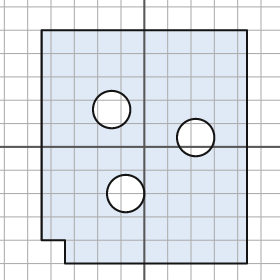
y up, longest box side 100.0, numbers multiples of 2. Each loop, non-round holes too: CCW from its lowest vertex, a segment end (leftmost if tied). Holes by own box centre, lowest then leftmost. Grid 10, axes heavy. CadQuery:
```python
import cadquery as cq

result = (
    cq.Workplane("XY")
    .moveTo(-34.0, -50.0)
    .lineTo(44.0, -50.0)
    .lineTo(44.0, 50.0)
    .lineTo(-44.0, 50.0)
    .lineTo(-44.0, -40.0)
    .lineTo(-34.0, -40.0)
    .close()
    .moveTo(-8.0, -20.0)
    .circle(8.0)
    .moveTo(22.0, 4.0)
    .circle(8.0)
    .moveTo(-14.0, 16.0)
    .circle(8.0)
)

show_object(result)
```